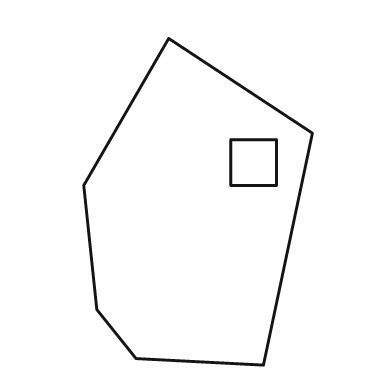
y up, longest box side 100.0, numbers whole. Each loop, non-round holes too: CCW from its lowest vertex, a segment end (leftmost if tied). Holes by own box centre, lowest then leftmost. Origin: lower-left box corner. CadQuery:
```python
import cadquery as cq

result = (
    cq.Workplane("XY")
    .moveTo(55.0, 0.0)
    .lineTo(70.0, 71.0)
    .lineTo(26.0, 100.0)
    .lineTo(0.0, 55.0)
    .lineTo(4.0, 17.0)
    .lineTo(16.0, 2.0)
    .close()
    .moveTo(45.0, 55.0)
    .lineTo(59.0, 55.0)
    .lineTo(59.0, 69.0)
    .lineTo(45.0, 69.0)
    .close()
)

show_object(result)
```